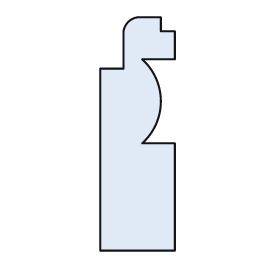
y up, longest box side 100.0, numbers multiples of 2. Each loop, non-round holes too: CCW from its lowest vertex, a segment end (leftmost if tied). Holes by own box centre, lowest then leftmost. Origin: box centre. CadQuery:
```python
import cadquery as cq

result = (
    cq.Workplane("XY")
    .moveTo(-16.0, -50.0)
    .lineTo(16.0, -50.0)
    .lineTo(16.0, -4.0)
    .lineTo(2.0, -4.0)
    .threePointArc((10.0, 14.0), (2.0, 32.0))
    .lineTo(16.0, 32.0)
    .lineTo(16.0, 44.0)
    .lineTo(10.0, 44.0)
    .lineTo(10.0, 50.0)
    .lineTo(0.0, 50.0)
    .threePointArc((-4.0, 48.0), (-6.0, 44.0))
    .lineTo(-6.0, 28.0)
    .lineTo(-16.0, 28.0)
    .close()
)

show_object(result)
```